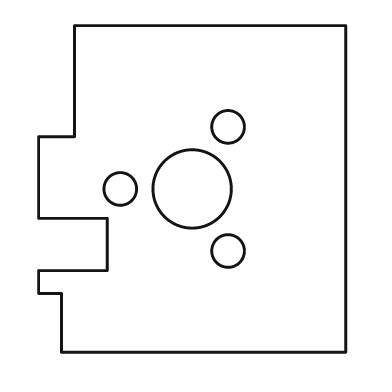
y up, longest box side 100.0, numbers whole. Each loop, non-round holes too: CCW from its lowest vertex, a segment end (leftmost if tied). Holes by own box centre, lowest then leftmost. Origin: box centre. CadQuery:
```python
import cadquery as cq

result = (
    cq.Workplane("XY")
    .moveTo(-40.0, -50.0)
    .lineTo(47.0, -50.0)
    .lineTo(47.0, 50.0)
    .lineTo(-36.0, 50.0)
    .lineTo(-36.0, 16.0)
    .lineTo(-47.0, 16.0)
    .lineTo(-47.0, -9.0)
    .lineTo(-26.0, -9.0)
    .lineTo(-26.0, -25.0)
    .lineTo(-47.0, -25.0)
    .lineTo(-47.0, -32.0)
    .lineTo(-40.0, -32.0)
    .close()
    .moveTo(11.0, -19.0)
    .circle(5.0)
    .moveTo(-22.0, 0.0)
    .circle(5.0)
    .moveTo(0.0, 0.0)
    .circle(12.0)
    .moveTo(11.0, 19.0)
    .circle(5.0)
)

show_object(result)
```